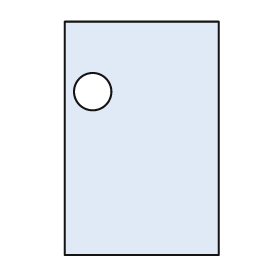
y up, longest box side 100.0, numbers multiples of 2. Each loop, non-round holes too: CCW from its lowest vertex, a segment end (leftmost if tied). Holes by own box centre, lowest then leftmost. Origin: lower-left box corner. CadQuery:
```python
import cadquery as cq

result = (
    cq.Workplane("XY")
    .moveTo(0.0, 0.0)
    .lineTo(66.0, 0.0)
    .lineTo(66.0, 100.0)
    .lineTo(0.0, 100.0)
    .close()
    .moveTo(12.0, 70.0)
    .circle(8.0)
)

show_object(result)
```